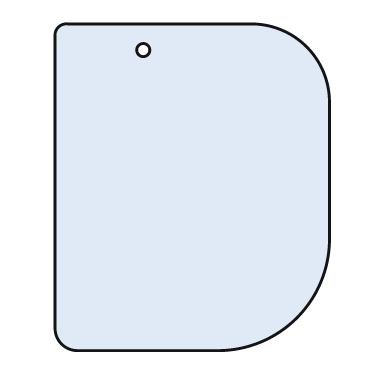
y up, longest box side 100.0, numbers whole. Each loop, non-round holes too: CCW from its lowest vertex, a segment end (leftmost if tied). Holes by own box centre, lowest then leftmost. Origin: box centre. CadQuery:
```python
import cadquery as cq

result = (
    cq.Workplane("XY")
    .moveTo(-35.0, -50.0)
    .lineTo(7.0, -50.0)
    .threePointArc((32.0, -40.0), (42.0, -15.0))
    .lineTo(42.0, 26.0)
    .threePointArc((35.0, 43.0), (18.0, 50.0))
    .lineTo(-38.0, 50.0)
    .threePointArc((-41.0, 49.0), (-42.0, 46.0))
    .lineTo(-42.0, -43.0)
    .threePointArc((-40.0, -48.0), (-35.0, -50.0))
    .close()
    .moveTo(-15.0, 42.0)
    .circle(2.0)
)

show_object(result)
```